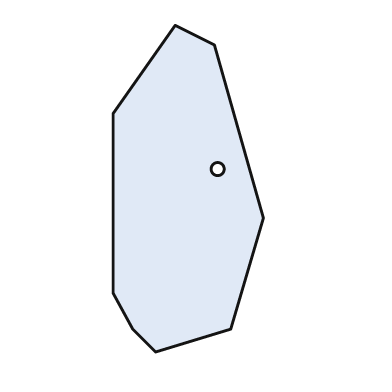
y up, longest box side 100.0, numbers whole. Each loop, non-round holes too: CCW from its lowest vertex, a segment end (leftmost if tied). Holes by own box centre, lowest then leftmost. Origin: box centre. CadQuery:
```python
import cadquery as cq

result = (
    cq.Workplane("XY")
    .moveTo(-10.0, -50.0)
    .lineTo(13.0, -43.0)
    .lineTo(23.0, -9.0)
    .lineTo(8.0, 44.0)
    .lineTo(-4.0, 50.0)
    .lineTo(-23.0, 23.0)
    .lineTo(-23.0, -32.0)
    .lineTo(-17.0, -43.0)
    .close()
    .moveTo(9.0, 6.0)
    .circle(2.0)
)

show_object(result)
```